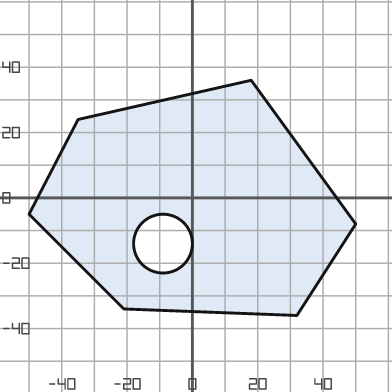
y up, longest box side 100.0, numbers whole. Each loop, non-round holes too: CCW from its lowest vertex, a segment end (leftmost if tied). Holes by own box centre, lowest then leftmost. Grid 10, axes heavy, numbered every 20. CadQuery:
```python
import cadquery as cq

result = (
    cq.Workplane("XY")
    .moveTo(32.0, -36.0)
    .lineTo(50.0, -8.0)
    .lineTo(18.0, 36.0)
    .lineTo(-35.0, 24.0)
    .lineTo(-50.0, -5.0)
    .lineTo(-21.0, -34.0)
    .close()
    .moveTo(-9.0, -14.0)
    .circle(9.0)
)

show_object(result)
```